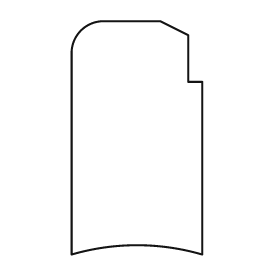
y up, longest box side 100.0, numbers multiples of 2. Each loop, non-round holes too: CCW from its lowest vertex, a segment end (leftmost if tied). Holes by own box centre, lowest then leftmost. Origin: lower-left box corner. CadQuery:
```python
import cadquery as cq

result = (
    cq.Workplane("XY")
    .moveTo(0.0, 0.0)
    .threePointArc((28.0, 4.0), (56.0, 0.0))
    .lineTo(56.0, 74.0)
    .lineTo(50.0, 74.0)
    .lineTo(50.0, 94.0)
    .lineTo(38.0, 100.0)
    .lineTo(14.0, 100.0)
    .threePointArc((4.0, 96.0), (0.0, 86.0))
    .close()
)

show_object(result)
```